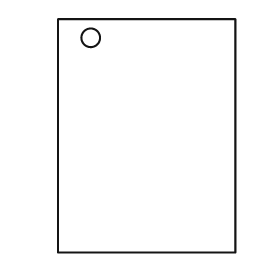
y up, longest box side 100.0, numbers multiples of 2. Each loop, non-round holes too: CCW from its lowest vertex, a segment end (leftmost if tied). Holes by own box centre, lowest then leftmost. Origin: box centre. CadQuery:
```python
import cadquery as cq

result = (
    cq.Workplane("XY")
    .moveTo(-38.0, -50.0)
    .lineTo(38.0, -50.0)
    .lineTo(38.0, 50.0)
    .lineTo(-38.0, 50.0)
    .close()
    .moveTo(-24.0, 42.0)
    .circle(4.0)
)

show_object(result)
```